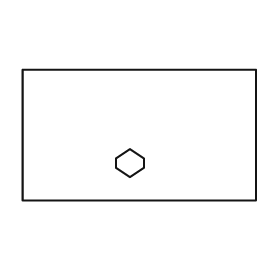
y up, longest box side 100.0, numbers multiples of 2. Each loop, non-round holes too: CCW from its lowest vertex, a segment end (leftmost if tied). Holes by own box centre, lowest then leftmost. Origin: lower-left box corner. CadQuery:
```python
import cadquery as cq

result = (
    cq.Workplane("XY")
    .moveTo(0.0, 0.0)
    .lineTo(100.0, 0.0)
    .lineTo(100.0, 56.0)
    .lineTo(0.0, 56.0)
    .close()
    .moveTo(46.0, 10.0)
    .lineTo(52.0, 14.0)
    .lineTo(52.0, 18.0)
    .lineTo(46.0, 22.0)
    .lineTo(40.0, 18.0)
    .lineTo(40.0, 14.0)
    .close()
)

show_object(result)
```